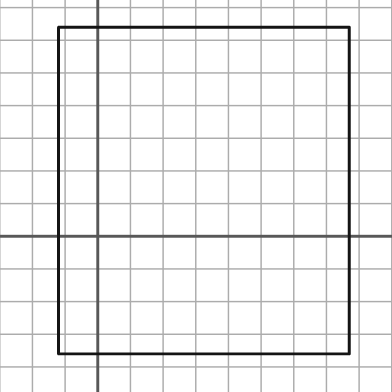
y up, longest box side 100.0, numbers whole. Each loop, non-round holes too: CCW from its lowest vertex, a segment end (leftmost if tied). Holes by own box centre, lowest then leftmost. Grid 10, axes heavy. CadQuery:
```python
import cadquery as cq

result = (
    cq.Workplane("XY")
    .moveTo(-12.0, -36.0)
    .lineTo(77.0, -36.0)
    .lineTo(77.0, 64.0)
    .lineTo(-12.0, 64.0)
    .close()
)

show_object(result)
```